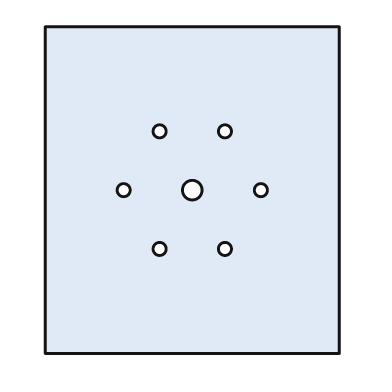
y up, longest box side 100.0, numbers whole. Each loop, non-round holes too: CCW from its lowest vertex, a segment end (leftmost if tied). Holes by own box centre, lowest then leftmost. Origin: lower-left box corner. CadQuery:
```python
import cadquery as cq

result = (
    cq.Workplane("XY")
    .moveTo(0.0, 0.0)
    .lineTo(90.0, 0.0)
    .lineTo(90.0, 100.0)
    .lineTo(0.0, 100.0)
    .close()
    .moveTo(35.0, 32.0)
    .circle(2.0)
    .moveTo(55.0, 32.0)
    .circle(2.0)
    .moveTo(24.0, 50.0)
    .circle(2.0)
    .moveTo(45.0, 50.0)
    .circle(3.0)
    .moveTo(66.0, 50.0)
    .circle(2.0)
    .moveTo(35.0, 68.0)
    .circle(2.0)
    .moveTo(55.0, 68.0)
    .circle(2.0)
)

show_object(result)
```